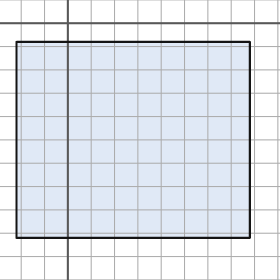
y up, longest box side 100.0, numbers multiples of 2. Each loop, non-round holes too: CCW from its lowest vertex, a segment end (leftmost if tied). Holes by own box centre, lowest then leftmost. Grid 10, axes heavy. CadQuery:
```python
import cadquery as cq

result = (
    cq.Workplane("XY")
    .moveTo(-22.0, -92.0)
    .lineTo(78.0, -92.0)
    .lineTo(78.0, -8.0)
    .lineTo(-22.0, -8.0)
    .close()
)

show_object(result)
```